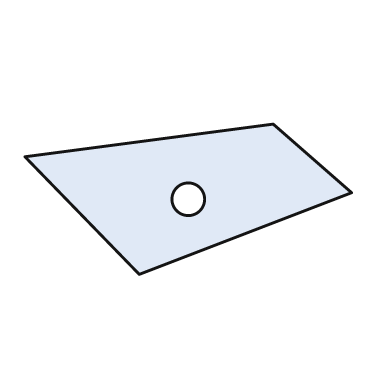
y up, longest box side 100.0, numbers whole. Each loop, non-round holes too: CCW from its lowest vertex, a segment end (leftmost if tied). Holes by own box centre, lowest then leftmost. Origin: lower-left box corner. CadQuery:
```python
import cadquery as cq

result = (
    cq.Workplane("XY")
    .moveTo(35.0, 0.0)
    .lineTo(100.0, 25.0)
    .lineTo(76.0, 46.0)
    .lineTo(0.0, 36.0)
    .close()
    .moveTo(50.0, 23.0)
    .circle(5.0)
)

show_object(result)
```